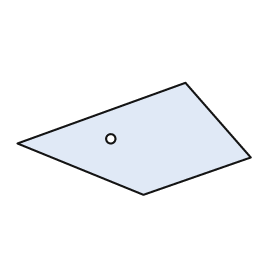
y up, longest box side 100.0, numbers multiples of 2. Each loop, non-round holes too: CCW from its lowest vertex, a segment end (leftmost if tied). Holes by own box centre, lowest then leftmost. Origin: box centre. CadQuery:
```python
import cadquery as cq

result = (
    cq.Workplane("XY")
    .moveTo(4.0, -24.0)
    .lineTo(50.0, -8.0)
    .lineTo(22.0, 24.0)
    .lineTo(-50.0, -2.0)
    .close()
    .moveTo(-10.0, 0.0)
    .circle(2.0)
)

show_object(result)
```